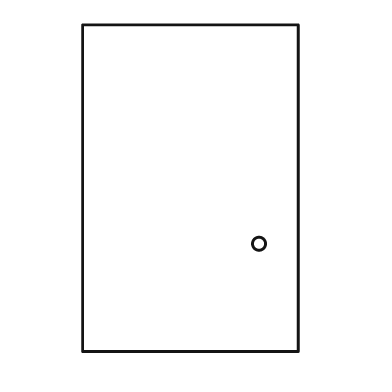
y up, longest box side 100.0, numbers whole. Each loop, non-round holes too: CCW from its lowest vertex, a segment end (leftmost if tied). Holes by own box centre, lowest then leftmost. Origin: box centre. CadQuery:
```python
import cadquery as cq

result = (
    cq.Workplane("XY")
    .moveTo(-33.0, -50.0)
    .lineTo(33.0, -50.0)
    .lineTo(33.0, 50.0)
    .lineTo(-33.0, 50.0)
    .close()
    .moveTo(21.0, -17.0)
    .circle(2.0)
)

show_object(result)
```